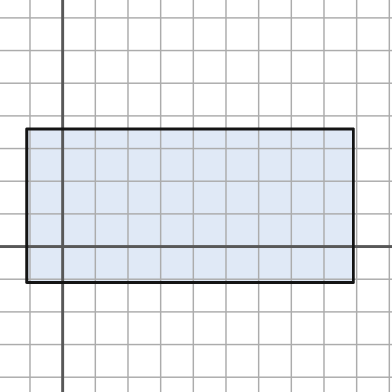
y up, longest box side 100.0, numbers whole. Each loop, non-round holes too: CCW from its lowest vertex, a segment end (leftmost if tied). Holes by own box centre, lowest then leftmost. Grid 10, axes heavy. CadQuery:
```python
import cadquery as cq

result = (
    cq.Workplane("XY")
    .moveTo(-11.0, -11.0)
    .lineTo(89.0, -11.0)
    .lineTo(89.0, 36.0)
    .lineTo(-11.0, 36.0)
    .close()
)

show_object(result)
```